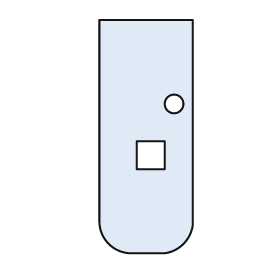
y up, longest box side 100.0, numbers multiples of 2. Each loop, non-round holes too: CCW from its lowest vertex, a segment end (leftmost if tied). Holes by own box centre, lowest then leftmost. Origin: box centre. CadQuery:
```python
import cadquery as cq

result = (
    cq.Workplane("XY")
    .moveTo(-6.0, -50.0)
    .lineTo(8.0, -50.0)
    .threePointArc((16.0, -46.0), (20.0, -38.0))
    .lineTo(20.0, 50.0)
    .lineTo(-20.0, 50.0)
    .lineTo(-20.0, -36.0)
    .threePointArc((-16.0, -46.0), (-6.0, -50.0))
    .close()
    .moveTo(-4.0, -14.0)
    .lineTo(8.0, -14.0)
    .lineTo(8.0, -2.0)
    .lineTo(-4.0, -2.0)
    .close()
    .moveTo(12.0, 14.0)
    .circle(4.0)
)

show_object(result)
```